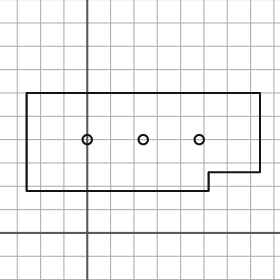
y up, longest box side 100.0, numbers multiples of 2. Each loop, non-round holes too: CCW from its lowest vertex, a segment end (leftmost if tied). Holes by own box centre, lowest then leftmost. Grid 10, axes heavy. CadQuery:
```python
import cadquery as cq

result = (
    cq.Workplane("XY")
    .moveTo(-26.0, 18.0)
    .lineTo(52.0, 18.0)
    .lineTo(52.0, 26.0)
    .lineTo(74.0, 26.0)
    .lineTo(74.0, 60.0)
    .lineTo(-26.0, 60.0)
    .close()
    .moveTo(0.0, 40.0)
    .circle(2.0)
    .moveTo(24.0, 40.0)
    .circle(2.0)
    .moveTo(48.0, 40.0)
    .circle(2.0)
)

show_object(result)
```